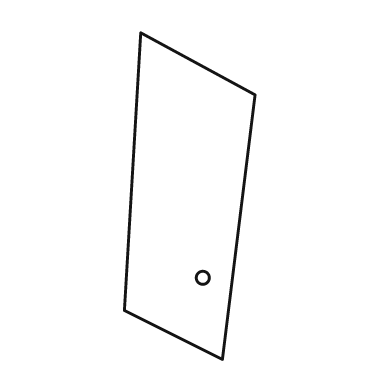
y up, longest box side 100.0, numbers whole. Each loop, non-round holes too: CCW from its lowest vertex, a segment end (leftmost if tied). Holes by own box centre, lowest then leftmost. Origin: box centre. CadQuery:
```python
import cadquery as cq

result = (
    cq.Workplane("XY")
    .moveTo(10.0, -50.0)
    .lineTo(20.0, 31.0)
    .lineTo(-15.0, 50.0)
    .lineTo(-20.0, -35.0)
    .close()
    .moveTo(4.0, -25.0)
    .circle(2.0)
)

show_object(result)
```